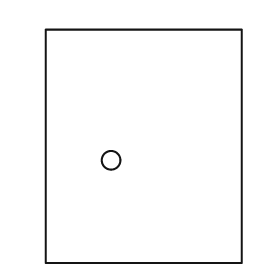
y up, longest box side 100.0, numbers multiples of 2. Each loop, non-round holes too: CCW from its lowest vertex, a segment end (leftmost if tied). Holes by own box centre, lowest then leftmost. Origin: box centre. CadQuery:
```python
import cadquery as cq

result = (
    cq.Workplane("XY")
    .moveTo(-42.0, -50.0)
    .lineTo(42.0, -50.0)
    .lineTo(42.0, 50.0)
    .lineTo(-42.0, 50.0)
    .close()
    .moveTo(-14.0, -6.0)
    .circle(4.0)
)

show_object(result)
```